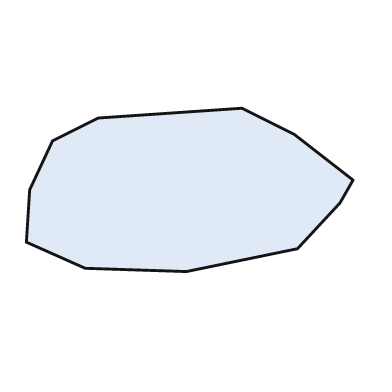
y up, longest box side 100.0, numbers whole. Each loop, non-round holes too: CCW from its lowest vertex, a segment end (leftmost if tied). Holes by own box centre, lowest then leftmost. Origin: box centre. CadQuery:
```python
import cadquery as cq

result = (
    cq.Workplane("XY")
    .moveTo(-1.0, -25.0)
    .lineTo(33.0, -18.0)
    .lineTo(46.0, -4.0)
    .lineTo(50.0, 3.0)
    .lineTo(32.0, 17.0)
    .lineTo(16.0, 25.0)
    .lineTo(-28.0, 22.0)
    .lineTo(-42.0, 15.0)
    .lineTo(-49.0, 0.0)
    .lineTo(-50.0, -16.0)
    .lineTo(-32.0, -24.0)
    .close()
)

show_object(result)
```